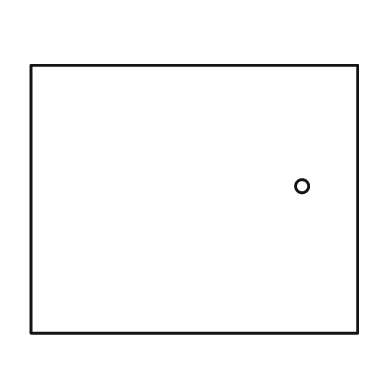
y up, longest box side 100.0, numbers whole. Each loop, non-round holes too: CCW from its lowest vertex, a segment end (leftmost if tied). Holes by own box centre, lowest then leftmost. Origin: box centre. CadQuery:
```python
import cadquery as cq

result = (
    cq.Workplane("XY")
    .moveTo(-50.0, -41.0)
    .lineTo(50.0, -41.0)
    .lineTo(50.0, 41.0)
    .lineTo(-50.0, 41.0)
    .close()
    .moveTo(33.0, 4.0)
    .circle(2.0)
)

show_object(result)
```